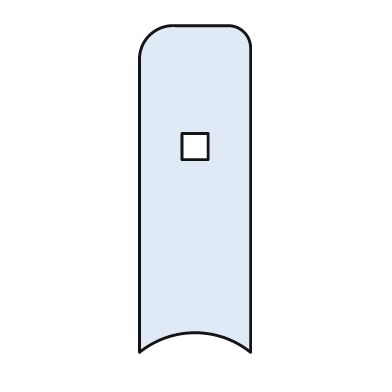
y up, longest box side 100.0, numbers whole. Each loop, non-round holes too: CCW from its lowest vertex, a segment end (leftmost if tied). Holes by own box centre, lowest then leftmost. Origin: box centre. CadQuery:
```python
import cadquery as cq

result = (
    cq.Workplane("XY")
    .moveTo(-17.0, -50.0)
    .threePointArc((0.0, -44.0), (17.0, -50.0))
    .lineTo(17.0, 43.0)
    .threePointArc((15.0, 48.0), (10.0, 50.0))
    .lineTo(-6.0, 50.0)
    .threePointArc((-14.0, 47.0), (-17.0, 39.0))
    .close()
    .moveTo(-4.0, 9.0)
    .lineTo(4.0, 9.0)
    .lineTo(4.0, 17.0)
    .lineTo(-4.0, 17.0)
    .close()
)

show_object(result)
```